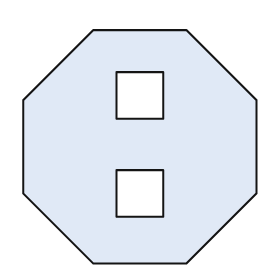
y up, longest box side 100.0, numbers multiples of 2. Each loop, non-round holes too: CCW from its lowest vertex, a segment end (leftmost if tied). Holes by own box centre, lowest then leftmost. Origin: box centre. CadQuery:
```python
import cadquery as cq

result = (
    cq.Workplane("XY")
    .moveTo(-20.0, -50.0)
    .lineTo(20.0, -50.0)
    .lineTo(50.0, -20.0)
    .lineTo(50.0, 20.0)
    .lineTo(20.0, 50.0)
    .lineTo(-20.0, 50.0)
    .lineTo(-50.0, 20.0)
    .lineTo(-50.0, -20.0)
    .close()
    .moveTo(-10.0, -30.0)
    .lineTo(10.0, -30.0)
    .lineTo(10.0, -10.0)
    .lineTo(-10.0, -10.0)
    .close()
    .moveTo(-10.0, 12.0)
    .lineTo(10.0, 12.0)
    .lineTo(10.0, 32.0)
    .lineTo(-10.0, 32.0)
    .close()
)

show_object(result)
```